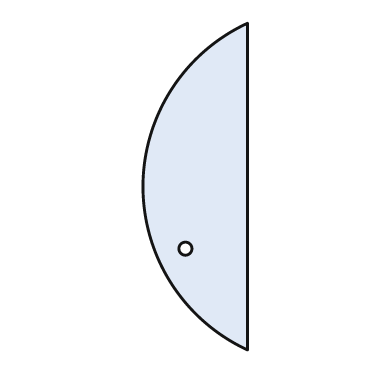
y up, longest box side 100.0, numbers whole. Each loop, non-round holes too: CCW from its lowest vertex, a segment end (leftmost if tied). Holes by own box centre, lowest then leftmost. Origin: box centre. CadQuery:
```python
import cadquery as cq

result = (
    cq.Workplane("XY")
    .moveTo(16.0, -50.0)
    .lineTo(16.0, 50.0)
    .threePointArc((-16.0, 0.0), (16.0, -50.0))
    .close()
    .moveTo(-3.0, -19.0)
    .circle(2.0)
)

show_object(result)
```